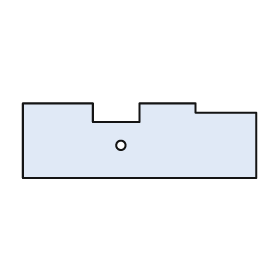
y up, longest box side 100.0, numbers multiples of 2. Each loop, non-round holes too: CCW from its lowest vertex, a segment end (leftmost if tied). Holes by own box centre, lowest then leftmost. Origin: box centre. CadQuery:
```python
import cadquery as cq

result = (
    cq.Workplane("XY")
    .moveTo(-50.0, -16.0)
    .lineTo(50.0, -16.0)
    .lineTo(50.0, 12.0)
    .lineTo(24.0, 12.0)
    .lineTo(24.0, 16.0)
    .lineTo(0.0, 16.0)
    .lineTo(0.0, 8.0)
    .lineTo(-20.0, 8.0)
    .lineTo(-20.0, 16.0)
    .lineTo(-50.0, 16.0)
    .close()
    .moveTo(-8.0, -2.0)
    .circle(2.0)
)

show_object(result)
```